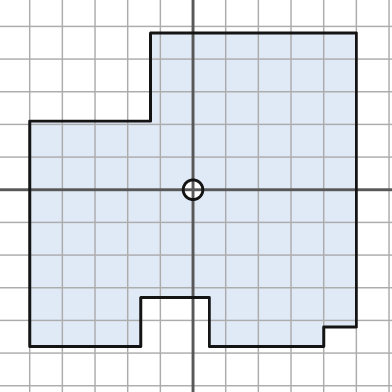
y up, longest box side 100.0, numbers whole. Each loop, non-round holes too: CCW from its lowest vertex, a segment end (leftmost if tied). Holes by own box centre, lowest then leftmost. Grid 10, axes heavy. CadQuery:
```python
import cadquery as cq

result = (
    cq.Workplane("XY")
    .moveTo(-50.0, -48.0)
    .lineTo(-16.0, -48.0)
    .lineTo(-16.0, -33.0)
    .lineTo(5.0, -33.0)
    .lineTo(5.0, -48.0)
    .lineTo(40.0, -48.0)
    .lineTo(40.0, -42.0)
    .lineTo(50.0, -42.0)
    .lineTo(50.0, 48.0)
    .lineTo(-13.0, 48.0)
    .lineTo(-13.0, 21.0)
    .lineTo(-50.0, 21.0)
    .close()
    .moveTo(0.0, 0.0)
    .circle(3.0)
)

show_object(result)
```